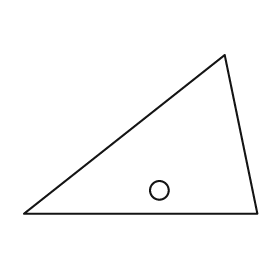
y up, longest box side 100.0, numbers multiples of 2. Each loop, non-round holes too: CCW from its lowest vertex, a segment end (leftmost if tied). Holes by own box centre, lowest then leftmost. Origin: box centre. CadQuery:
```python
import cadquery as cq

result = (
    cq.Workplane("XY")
    .moveTo(-50.0, -34.0)
    .lineTo(50.0, -34.0)
    .lineTo(36.0, 34.0)
    .close()
    .moveTo(8.0, -24.0)
    .circle(4.0)
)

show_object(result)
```